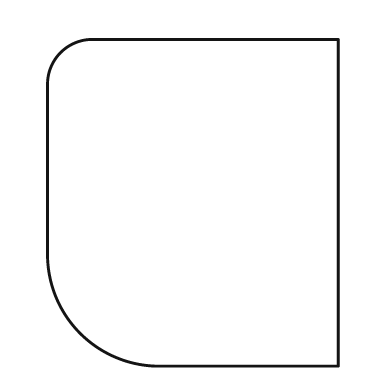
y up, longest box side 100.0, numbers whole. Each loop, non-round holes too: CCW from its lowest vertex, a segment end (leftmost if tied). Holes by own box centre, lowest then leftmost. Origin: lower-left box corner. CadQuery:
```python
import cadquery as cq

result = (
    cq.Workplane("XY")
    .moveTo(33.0, 0.0)
    .lineTo(89.0, 0.0)
    .lineTo(89.0, 100.0)
    .lineTo(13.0, 100.0)
    .threePointArc((4.0, 96.0), (0.0, 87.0))
    .lineTo(0.0, 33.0)
    .threePointArc((10.0, 10.0), (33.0, 0.0))
    .close()
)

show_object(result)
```